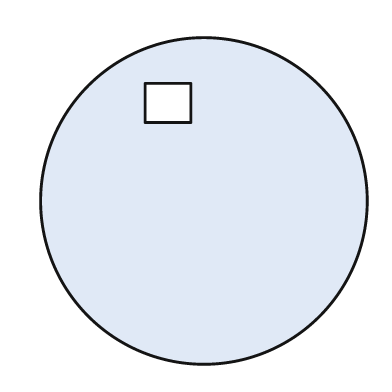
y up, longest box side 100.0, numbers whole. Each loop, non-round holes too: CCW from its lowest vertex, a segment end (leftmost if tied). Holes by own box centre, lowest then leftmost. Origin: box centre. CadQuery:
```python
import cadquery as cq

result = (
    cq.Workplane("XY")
    .moveTo(0.0, 0.0)
    .circle(50.0)
    .moveTo(-18.0, 24.0)
    .lineTo(-4.0, 24.0)
    .lineTo(-4.0, 36.0)
    .lineTo(-18.0, 36.0)
    .close()
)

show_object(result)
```